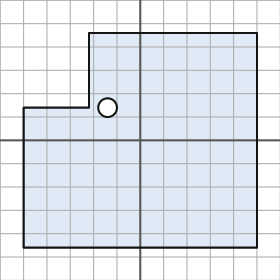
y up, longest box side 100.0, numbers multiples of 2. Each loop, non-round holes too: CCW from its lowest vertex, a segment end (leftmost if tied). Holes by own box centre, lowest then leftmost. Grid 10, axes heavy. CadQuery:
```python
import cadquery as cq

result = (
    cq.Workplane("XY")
    .moveTo(-50.0, -46.0)
    .lineTo(50.0, -46.0)
    .lineTo(50.0, 46.0)
    .lineTo(-22.0, 46.0)
    .lineTo(-22.0, 14.0)
    .lineTo(-50.0, 14.0)
    .close()
    .moveTo(-14.0, 14.0)
    .circle(4.0)
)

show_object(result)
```